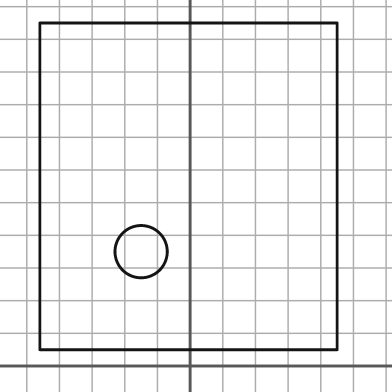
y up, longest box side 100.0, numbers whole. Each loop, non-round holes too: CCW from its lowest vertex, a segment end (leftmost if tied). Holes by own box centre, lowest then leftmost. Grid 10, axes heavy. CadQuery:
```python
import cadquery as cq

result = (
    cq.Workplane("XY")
    .moveTo(-46.0, 5.0)
    .lineTo(45.0, 5.0)
    .lineTo(45.0, 105.0)
    .lineTo(-46.0, 105.0)
    .close()
    .moveTo(-15.0, 35.0)
    .circle(8.0)
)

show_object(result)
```